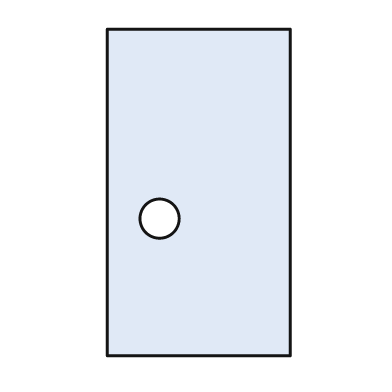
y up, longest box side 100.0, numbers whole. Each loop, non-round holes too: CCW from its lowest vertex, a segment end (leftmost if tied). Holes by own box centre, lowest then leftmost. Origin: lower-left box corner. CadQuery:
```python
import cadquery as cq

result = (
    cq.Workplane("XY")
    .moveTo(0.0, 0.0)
    .lineTo(56.0, 0.0)
    .lineTo(56.0, 100.0)
    .lineTo(0.0, 100.0)
    .close()
    .moveTo(16.0, 42.0)
    .circle(6.0)
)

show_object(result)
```